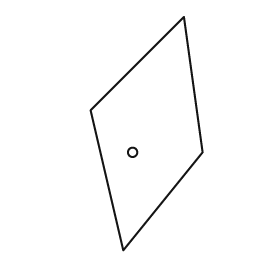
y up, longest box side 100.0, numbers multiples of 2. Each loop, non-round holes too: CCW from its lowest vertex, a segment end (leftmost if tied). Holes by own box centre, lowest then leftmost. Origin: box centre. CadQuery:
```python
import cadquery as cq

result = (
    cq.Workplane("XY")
    .moveTo(-10.0, -50.0)
    .lineTo(24.0, -8.0)
    .lineTo(16.0, 50.0)
    .lineTo(-24.0, 10.0)
    .close()
    .moveTo(-6.0, -8.0)
    .circle(2.0)
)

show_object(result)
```